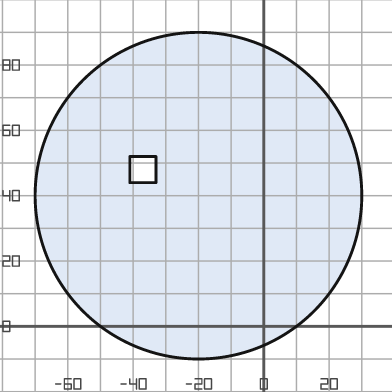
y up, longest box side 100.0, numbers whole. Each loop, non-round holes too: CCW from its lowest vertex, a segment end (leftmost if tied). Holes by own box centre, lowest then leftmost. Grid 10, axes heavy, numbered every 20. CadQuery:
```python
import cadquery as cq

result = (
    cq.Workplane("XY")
    .moveTo(-20.0, 40.0)
    .circle(50.0)
    .moveTo(-41.0, 44.0)
    .lineTo(-33.0, 44.0)
    .lineTo(-33.0, 52.0)
    .lineTo(-41.0, 52.0)
    .close()
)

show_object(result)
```